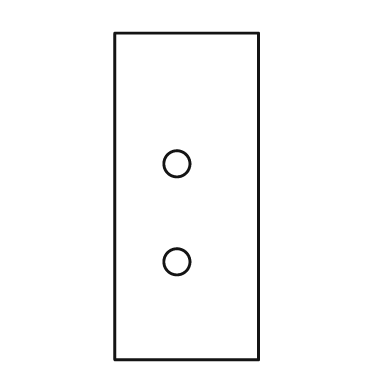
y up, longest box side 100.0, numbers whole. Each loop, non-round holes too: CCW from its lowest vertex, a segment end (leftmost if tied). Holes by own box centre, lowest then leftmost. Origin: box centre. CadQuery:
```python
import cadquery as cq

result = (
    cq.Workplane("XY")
    .moveTo(-22.0, -50.0)
    .lineTo(22.0, -50.0)
    .lineTo(22.0, 50.0)
    .lineTo(-22.0, 50.0)
    .close()
    .moveTo(-3.0, -20.0)
    .circle(4.0)
    .moveTo(-3.0, 10.0)
    .circle(4.0)
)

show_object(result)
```